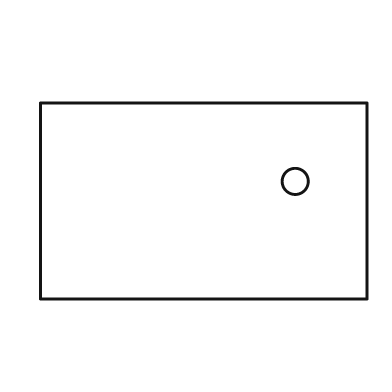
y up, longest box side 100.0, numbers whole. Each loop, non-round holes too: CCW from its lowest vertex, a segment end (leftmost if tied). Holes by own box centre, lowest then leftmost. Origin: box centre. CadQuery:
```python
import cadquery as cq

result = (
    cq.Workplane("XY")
    .moveTo(-50.0, -30.0)
    .lineTo(50.0, -30.0)
    .lineTo(50.0, 30.0)
    .lineTo(-50.0, 30.0)
    .close()
    .moveTo(28.0, 6.0)
    .circle(4.0)
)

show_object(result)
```